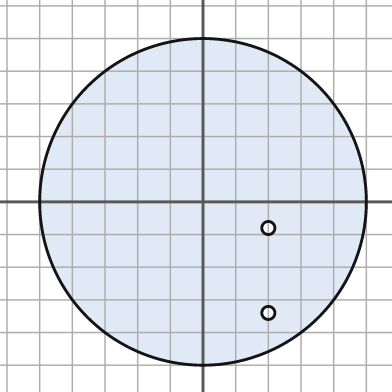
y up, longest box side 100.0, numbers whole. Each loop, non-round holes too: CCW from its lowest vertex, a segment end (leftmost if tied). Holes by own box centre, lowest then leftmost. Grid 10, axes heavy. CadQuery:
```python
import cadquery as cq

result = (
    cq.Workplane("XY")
    .moveTo(0.0, 0.0)
    .circle(50.0)
    .moveTo(20.0, -34.0)
    .circle(2.0)
    .moveTo(20.0, -8.0)
    .circle(2.0)
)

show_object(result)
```